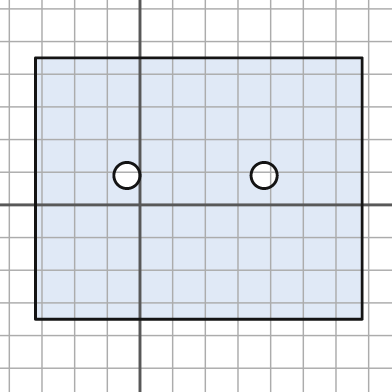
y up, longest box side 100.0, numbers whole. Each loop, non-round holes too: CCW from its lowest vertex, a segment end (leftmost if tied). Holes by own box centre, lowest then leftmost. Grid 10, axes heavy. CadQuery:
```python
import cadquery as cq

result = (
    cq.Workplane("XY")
    .moveTo(-32.0, -35.0)
    .lineTo(68.0, -35.0)
    .lineTo(68.0, 45.0)
    .lineTo(-32.0, 45.0)
    .close()
    .moveTo(-4.0, 9.0)
    .circle(4.0)
    .moveTo(38.0, 9.0)
    .circle(4.0)
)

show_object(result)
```